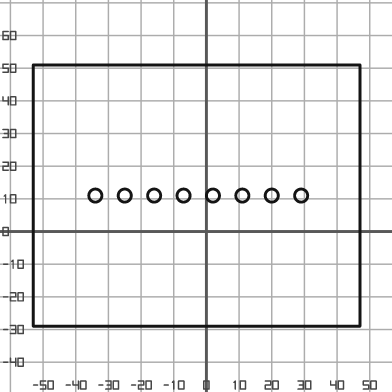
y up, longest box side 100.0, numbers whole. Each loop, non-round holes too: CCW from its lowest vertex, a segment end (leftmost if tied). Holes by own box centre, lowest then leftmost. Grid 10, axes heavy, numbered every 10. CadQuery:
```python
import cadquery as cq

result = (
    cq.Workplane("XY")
    .moveTo(-53.0, -29.0)
    .lineTo(47.0, -29.0)
    .lineTo(47.0, 51.0)
    .lineTo(-53.0, 51.0)
    .close()
    .moveTo(-34.0, 11.0)
    .circle(2.0)
    .moveTo(-25.0, 11.0)
    .circle(2.0)
    .moveTo(-16.0, 11.0)
    .circle(2.0)
    .moveTo(-7.0, 11.0)
    .circle(2.0)
    .moveTo(2.0, 11.0)
    .circle(2.0)
    .moveTo(11.0, 11.0)
    .circle(2.0)
    .moveTo(20.0, 11.0)
    .circle(2.0)
    .moveTo(29.0, 11.0)
    .circle(2.0)
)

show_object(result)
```